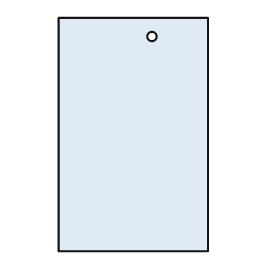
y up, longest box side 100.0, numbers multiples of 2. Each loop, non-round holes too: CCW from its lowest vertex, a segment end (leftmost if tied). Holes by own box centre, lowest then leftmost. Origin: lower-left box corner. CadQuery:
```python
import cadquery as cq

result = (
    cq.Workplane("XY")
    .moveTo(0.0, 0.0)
    .lineTo(64.0, 0.0)
    .lineTo(64.0, 100.0)
    .lineTo(0.0, 100.0)
    .close()
    .moveTo(40.0, 92.0)
    .circle(2.0)
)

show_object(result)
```